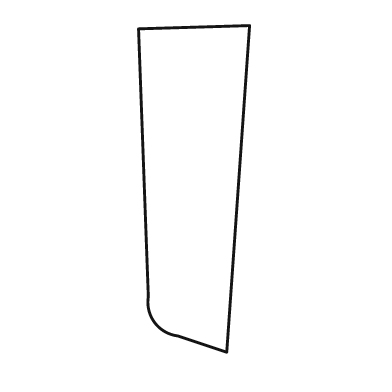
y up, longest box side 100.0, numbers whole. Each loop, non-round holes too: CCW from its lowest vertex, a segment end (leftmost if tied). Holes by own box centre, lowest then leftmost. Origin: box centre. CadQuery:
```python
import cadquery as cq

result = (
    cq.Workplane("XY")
    .moveTo(10.0, -50.0)
    .lineTo(17.0, 50.0)
    .lineTo(-17.0, 49.0)
    .lineTo(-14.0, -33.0)
    .threePointArc((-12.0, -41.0), (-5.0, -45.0))
    .close()
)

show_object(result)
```